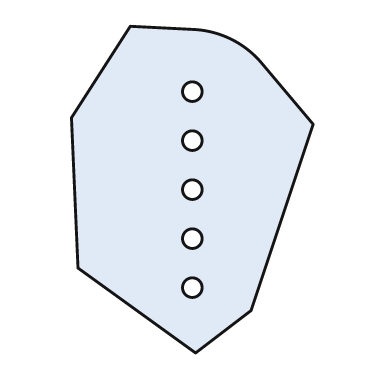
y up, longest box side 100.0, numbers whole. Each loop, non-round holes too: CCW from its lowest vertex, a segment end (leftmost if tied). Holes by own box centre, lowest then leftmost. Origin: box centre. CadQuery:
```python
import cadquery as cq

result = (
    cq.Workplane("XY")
    .moveTo(1.0, -50.0)
    .lineTo(18.0, -37.0)
    .lineTo(37.0, 20.0)
    .lineTo(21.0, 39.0)
    .threePointArc((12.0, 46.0), (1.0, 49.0))
    .lineTo(-19.0, 50.0)
    .lineTo(-37.0, 22.0)
    .lineTo(-35.0, -24.0)
    .close()
    .moveTo(0.0, -30.0)
    .circle(3.0)
    .moveTo(0.0, -15.0)
    .circle(3.0)
    .moveTo(0.0, 0.0)
    .circle(3.0)
    .moveTo(0.0, 15.0)
    .circle(3.0)
    .moveTo(0.0, 30.0)
    .circle(3.0)
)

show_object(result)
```